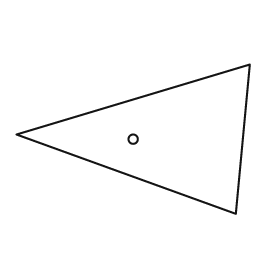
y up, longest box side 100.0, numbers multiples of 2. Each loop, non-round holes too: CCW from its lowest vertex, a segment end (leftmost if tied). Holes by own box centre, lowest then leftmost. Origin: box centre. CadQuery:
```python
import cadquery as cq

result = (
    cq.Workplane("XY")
    .moveTo(44.0, -32.0)
    .lineTo(50.0, 32.0)
    .lineTo(-50.0, 2.0)
    .close()
    .moveTo(0.0, 0.0)
    .circle(2.0)
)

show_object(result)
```